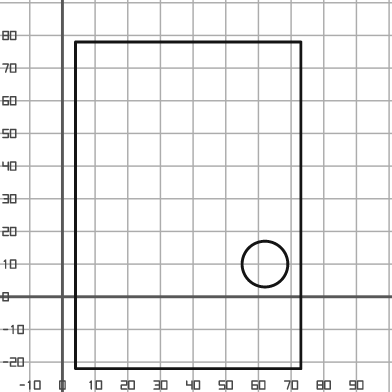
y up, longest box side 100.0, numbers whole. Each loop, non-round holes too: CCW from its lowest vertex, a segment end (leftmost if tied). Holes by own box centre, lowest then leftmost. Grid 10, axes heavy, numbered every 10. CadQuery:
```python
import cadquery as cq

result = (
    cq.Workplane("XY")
    .moveTo(4.0, -22.0)
    .lineTo(73.0, -22.0)
    .lineTo(73.0, 78.0)
    .lineTo(4.0, 78.0)
    .close()
    .moveTo(62.0, 10.0)
    .circle(7.0)
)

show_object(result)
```